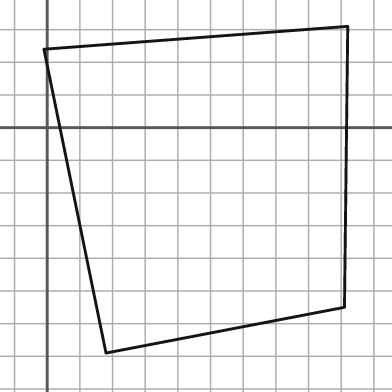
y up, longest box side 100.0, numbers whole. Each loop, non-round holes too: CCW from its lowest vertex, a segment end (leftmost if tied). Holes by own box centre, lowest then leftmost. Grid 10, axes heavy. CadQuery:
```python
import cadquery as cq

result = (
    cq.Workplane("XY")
    .moveTo(18.0, -69.0)
    .lineTo(91.0, -55.0)
    .lineTo(92.0, 31.0)
    .lineTo(-1.0, 24.0)
    .close()
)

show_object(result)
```